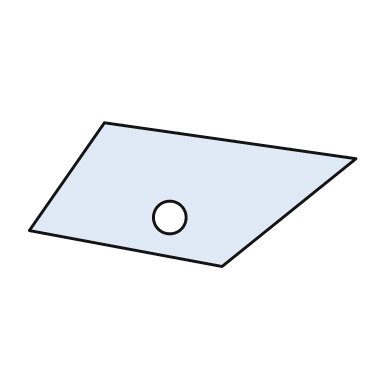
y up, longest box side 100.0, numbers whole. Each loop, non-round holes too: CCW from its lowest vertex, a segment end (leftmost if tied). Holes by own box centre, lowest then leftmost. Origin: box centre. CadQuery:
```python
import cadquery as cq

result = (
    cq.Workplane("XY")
    .moveTo(9.0, -22.0)
    .lineTo(50.0, 11.0)
    .lineTo(-27.0, 22.0)
    .lineTo(-50.0, -11.0)
    .close()
    .moveTo(-7.0, -7.0)
    .circle(5.0)
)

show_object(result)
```